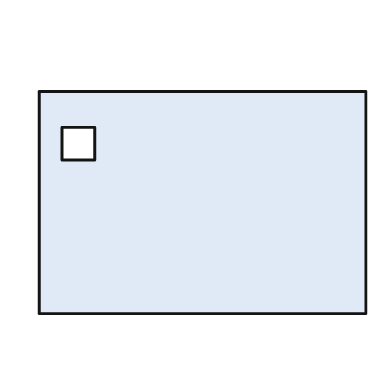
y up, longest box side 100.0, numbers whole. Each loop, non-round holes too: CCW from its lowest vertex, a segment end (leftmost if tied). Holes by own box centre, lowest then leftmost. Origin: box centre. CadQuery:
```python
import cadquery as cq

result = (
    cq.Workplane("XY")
    .moveTo(-50.0, -34.0)
    .lineTo(50.0, -34.0)
    .lineTo(50.0, 34.0)
    .lineTo(-50.0, 34.0)
    .close()
    .moveTo(-43.0, 13.0)
    .lineTo(-33.0, 13.0)
    .lineTo(-33.0, 23.0)
    .lineTo(-43.0, 23.0)
    .close()
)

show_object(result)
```